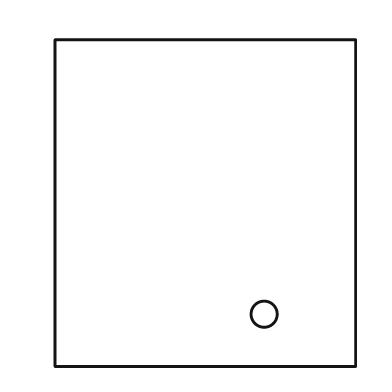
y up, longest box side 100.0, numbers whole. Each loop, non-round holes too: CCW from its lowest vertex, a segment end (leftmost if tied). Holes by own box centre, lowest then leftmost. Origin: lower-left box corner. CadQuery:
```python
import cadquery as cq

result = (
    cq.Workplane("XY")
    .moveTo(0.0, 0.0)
    .lineTo(92.0, 0.0)
    .lineTo(92.0, 100.0)
    .lineTo(0.0, 100.0)
    .close()
    .moveTo(64.0, 16.0)
    .circle(4.0)
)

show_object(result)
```